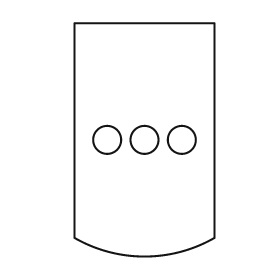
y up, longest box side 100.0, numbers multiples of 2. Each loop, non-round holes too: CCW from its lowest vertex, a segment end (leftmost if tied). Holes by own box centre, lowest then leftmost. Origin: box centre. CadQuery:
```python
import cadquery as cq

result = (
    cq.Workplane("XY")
    .moveTo(-30.0, -42.0)
    .threePointArc((0.0, -50.0), (30.0, -42.0))
    .lineTo(30.0, 50.0)
    .lineTo(-30.0, 50.0)
    .close()
    .moveTo(-16.0, 0.0)
    .circle(6.0)
    .moveTo(0.0, 0.0)
    .circle(6.0)
    .moveTo(16.0, 0.0)
    .circle(6.0)
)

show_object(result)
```